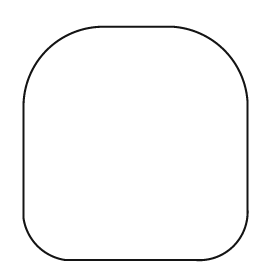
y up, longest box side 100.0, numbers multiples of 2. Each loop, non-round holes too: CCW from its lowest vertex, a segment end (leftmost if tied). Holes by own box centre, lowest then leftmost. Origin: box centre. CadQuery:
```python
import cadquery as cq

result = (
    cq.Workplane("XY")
    .moveTo(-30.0, -50.0)
    .lineTo(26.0, -50.0)
    .threePointArc((42.0, -44.0), (48.0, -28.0))
    .lineTo(48.0, 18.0)
    .threePointArc((38.0, 40.0), (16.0, 50.0))
    .lineTo(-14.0, 50.0)
    .threePointArc((-38.0, 40.0), (-48.0, 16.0))
    .lineTo(-48.0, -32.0)
    .threePointArc((-42.0, -44.0), (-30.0, -50.0))
    .close()
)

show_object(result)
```